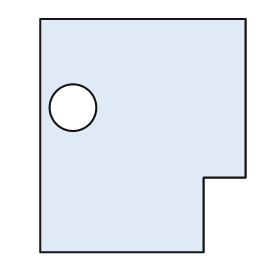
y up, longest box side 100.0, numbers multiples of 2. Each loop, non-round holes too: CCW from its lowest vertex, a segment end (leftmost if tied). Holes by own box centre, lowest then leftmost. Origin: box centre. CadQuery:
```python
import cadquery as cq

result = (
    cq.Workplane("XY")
    .moveTo(-44.0, -50.0)
    .lineTo(26.0, -50.0)
    .lineTo(26.0, -18.0)
    .lineTo(44.0, -18.0)
    .lineTo(44.0, 50.0)
    .lineTo(-44.0, 50.0)
    .close()
    .moveTo(-30.0, 12.0)
    .circle(10.0)
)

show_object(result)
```